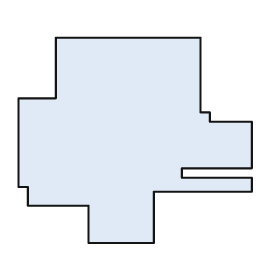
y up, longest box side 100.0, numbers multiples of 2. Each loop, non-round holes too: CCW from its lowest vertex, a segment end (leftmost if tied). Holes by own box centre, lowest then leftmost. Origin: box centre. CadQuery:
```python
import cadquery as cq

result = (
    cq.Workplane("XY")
    .moveTo(-20.0, -44.0)
    .lineTo(8.0, -44.0)
    .lineTo(8.0, -22.0)
    .lineTo(50.0, -22.0)
    .lineTo(50.0, -16.0)
    .lineTo(20.0, -16.0)
    .lineTo(20.0, -12.0)
    .lineTo(50.0, -12.0)
    .lineTo(50.0, 8.0)
    .lineTo(32.0, 8.0)
    .lineTo(32.0, 12.0)
    .lineTo(28.0, 12.0)
    .lineTo(28.0, 44.0)
    .lineTo(-34.0, 44.0)
    .lineTo(-34.0, 18.0)
    .lineTo(-50.0, 18.0)
    .lineTo(-50.0, -20.0)
    .lineTo(-46.0, -20.0)
    .lineTo(-46.0, -28.0)
    .lineTo(-20.0, -28.0)
    .close()
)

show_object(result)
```